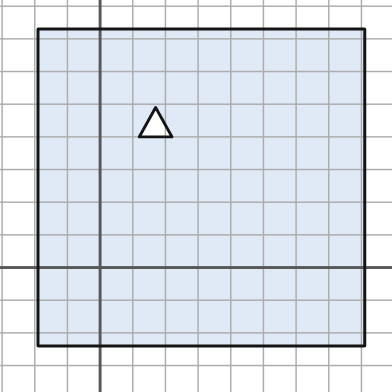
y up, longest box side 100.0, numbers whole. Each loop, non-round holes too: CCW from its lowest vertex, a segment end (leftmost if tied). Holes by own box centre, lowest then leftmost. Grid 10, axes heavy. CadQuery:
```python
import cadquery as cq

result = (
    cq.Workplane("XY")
    .moveTo(-19.0, -24.0)
    .lineTo(81.0, -24.0)
    .lineTo(81.0, 73.0)
    .lineTo(-19.0, 73.0)
    .close()
    .moveTo(12.0, 40.0)
    .lineTo(22.0, 40.0)
    .lineTo(17.0, 49.0)
    .close()
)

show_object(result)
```